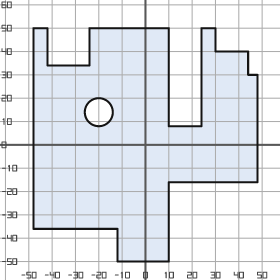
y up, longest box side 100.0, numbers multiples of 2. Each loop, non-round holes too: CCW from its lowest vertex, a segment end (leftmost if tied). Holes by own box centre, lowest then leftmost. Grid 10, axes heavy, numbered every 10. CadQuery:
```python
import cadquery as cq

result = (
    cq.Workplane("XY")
    .moveTo(-12.0, -50.0)
    .lineTo(10.0, -50.0)
    .lineTo(10.0, -16.0)
    .lineTo(48.0, -16.0)
    .lineTo(48.0, 30.0)
    .lineTo(44.0, 30.0)
    .lineTo(44.0, 40.0)
    .lineTo(30.0, 40.0)
    .lineTo(30.0, 50.0)
    .lineTo(24.0, 50.0)
    .lineTo(24.0, 8.0)
    .lineTo(10.0, 8.0)
    .lineTo(10.0, 50.0)
    .lineTo(-24.0, 50.0)
    .lineTo(-24.0, 34.0)
    .lineTo(-42.0, 34.0)
    .lineTo(-42.0, 50.0)
    .lineTo(-48.0, 50.0)
    .lineTo(-48.0, -36.0)
    .lineTo(-12.0, -36.0)
    .close()
    .moveTo(-20.0, 14.0)
    .circle(6.0)
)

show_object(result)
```